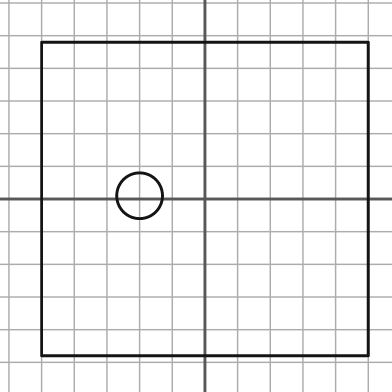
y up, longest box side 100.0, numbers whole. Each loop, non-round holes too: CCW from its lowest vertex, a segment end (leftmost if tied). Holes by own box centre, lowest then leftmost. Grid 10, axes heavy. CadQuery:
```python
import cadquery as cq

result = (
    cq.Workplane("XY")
    .moveTo(-50.0, -48.0)
    .lineTo(50.0, -48.0)
    .lineTo(50.0, 48.0)
    .lineTo(-50.0, 48.0)
    .close()
    .moveTo(-20.0, 1.0)
    .circle(7.0)
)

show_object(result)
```